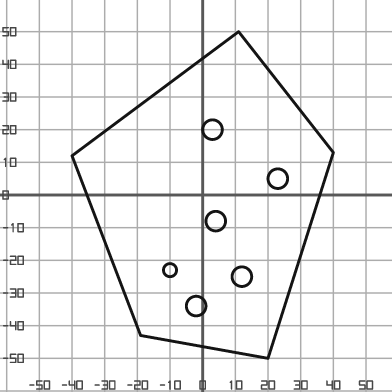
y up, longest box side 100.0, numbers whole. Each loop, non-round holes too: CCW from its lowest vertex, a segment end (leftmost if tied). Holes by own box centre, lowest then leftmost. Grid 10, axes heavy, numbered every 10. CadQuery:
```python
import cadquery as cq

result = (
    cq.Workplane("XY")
    .moveTo(20.0, -50.0)
    .lineTo(40.0, 13.0)
    .lineTo(11.0, 50.0)
    .lineTo(-40.0, 12.0)
    .lineTo(-19.0, -43.0)
    .close()
    .moveTo(-2.0, -34.0)
    .circle(3.0)
    .moveTo(12.0, -25.0)
    .circle(3.0)
    .moveTo(-10.0, -23.0)
    .circle(2.0)
    .moveTo(4.0, -8.0)
    .circle(3.0)
    .moveTo(23.0, 5.0)
    .circle(3.0)
    .moveTo(3.0, 20.0)
    .circle(3.0)
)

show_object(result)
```